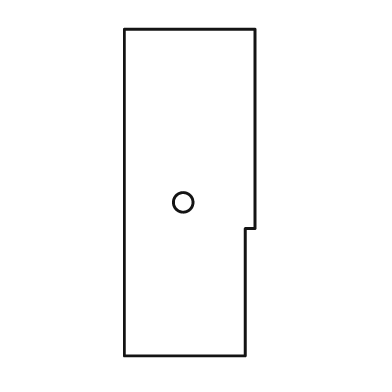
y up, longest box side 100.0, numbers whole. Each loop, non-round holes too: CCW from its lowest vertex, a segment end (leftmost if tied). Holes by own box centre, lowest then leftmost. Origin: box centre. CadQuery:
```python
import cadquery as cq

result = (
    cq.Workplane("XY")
    .moveTo(-20.0, -50.0)
    .lineTo(17.0, -50.0)
    .lineTo(17.0, -11.0)
    .lineTo(20.0, -11.0)
    .lineTo(20.0, 50.0)
    .lineTo(-20.0, 50.0)
    .close()
    .moveTo(-2.0, -3.0)
    .circle(3.0)
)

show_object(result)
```